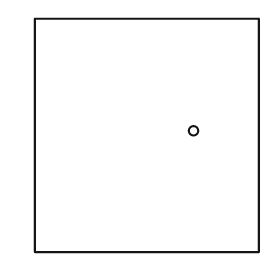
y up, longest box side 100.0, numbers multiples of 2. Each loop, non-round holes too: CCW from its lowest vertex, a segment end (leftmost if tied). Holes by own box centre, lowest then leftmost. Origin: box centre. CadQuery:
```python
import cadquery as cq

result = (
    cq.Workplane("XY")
    .moveTo(-48.0, -50.0)
    .lineTo(48.0, -50.0)
    .lineTo(48.0, 50.0)
    .lineTo(-48.0, 50.0)
    .close()
    .moveTo(20.0, 2.0)
    .circle(2.0)
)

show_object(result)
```